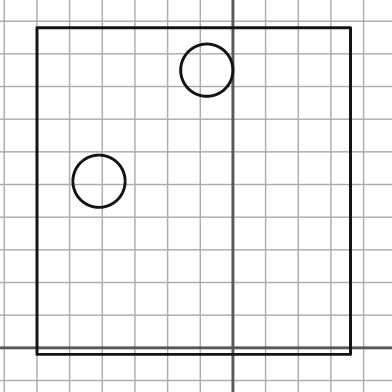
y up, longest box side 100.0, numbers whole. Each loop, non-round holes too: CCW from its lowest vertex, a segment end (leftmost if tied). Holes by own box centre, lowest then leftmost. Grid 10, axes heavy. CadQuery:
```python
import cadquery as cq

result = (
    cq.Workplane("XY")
    .moveTo(-60.0, -2.0)
    .lineTo(36.0, -2.0)
    .lineTo(36.0, 98.0)
    .lineTo(-60.0, 98.0)
    .close()
    .moveTo(-41.0, 51.0)
    .circle(8.0)
    .moveTo(-8.0, 85.0)
    .circle(8.0)
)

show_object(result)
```